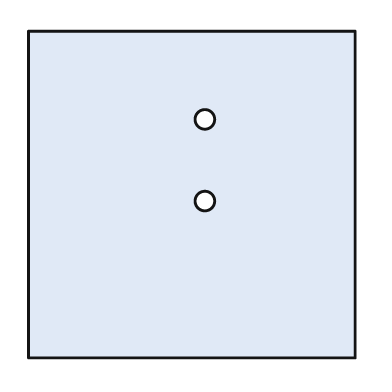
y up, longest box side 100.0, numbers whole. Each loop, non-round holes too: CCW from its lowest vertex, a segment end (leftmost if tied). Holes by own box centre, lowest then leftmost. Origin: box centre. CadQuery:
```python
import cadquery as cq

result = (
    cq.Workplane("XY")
    .moveTo(-50.0, -50.0)
    .lineTo(50.0, -50.0)
    .lineTo(50.0, 50.0)
    .lineTo(-50.0, 50.0)
    .close()
    .moveTo(4.0, -2.0)
    .circle(3.0)
    .moveTo(4.0, 23.0)
    .circle(3.0)
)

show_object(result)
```